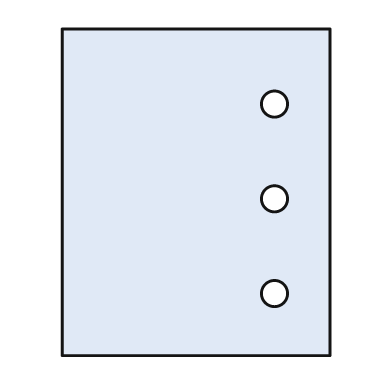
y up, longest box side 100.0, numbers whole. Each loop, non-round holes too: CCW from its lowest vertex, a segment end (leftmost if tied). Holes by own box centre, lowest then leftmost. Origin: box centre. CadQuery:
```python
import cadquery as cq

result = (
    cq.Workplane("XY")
    .moveTo(-41.0, -50.0)
    .lineTo(41.0, -50.0)
    .lineTo(41.0, 50.0)
    .lineTo(-41.0, 50.0)
    .close()
    .moveTo(24.0, -31.0)
    .circle(4.0)
    .moveTo(24.0, -2.0)
    .circle(4.0)
    .moveTo(24.0, 27.0)
    .circle(4.0)
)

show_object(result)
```